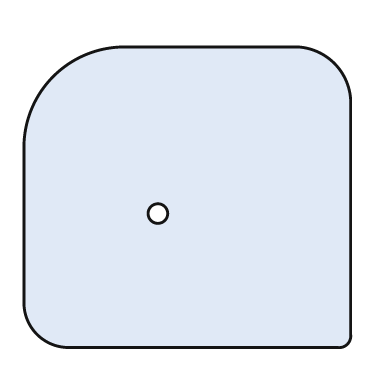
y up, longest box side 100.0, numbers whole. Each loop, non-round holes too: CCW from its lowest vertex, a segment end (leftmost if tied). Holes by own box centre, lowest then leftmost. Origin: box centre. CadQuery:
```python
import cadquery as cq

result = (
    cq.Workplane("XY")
    .moveTo(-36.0, -46.0)
    .lineTo(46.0, -46.0)
    .threePointArc((49.0, -45.0), (50.0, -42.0))
    .lineTo(50.0, 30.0)
    .threePointArc((45.0, 41.0), (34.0, 46.0))
    .lineTo(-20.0, 46.0)
    .threePointArc((-41.0, 37.0), (-50.0, 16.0))
    .lineTo(-50.0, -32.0)
    .threePointArc((-46.0, -42.0), (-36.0, -46.0))
    .close()
    .moveTo(-9.0, -5.0)
    .circle(3.0)
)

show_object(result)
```